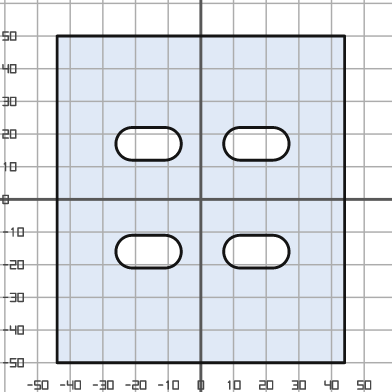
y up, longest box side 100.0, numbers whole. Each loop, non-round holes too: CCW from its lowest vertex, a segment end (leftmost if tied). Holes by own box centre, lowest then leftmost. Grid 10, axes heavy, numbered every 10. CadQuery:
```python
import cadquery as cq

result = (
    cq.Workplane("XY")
    .moveTo(-44.0, -50.0)
    .lineTo(44.0, -50.0)
    .lineTo(44.0, 50.0)
    .lineTo(-44.0, 50.0)
    .close()
    .moveTo(-21.0, -21.0)
    .lineTo(-11.0, -21.0)
    .threePointArc((-6.0, -16.0), (-11.0, -11.0))
    .lineTo(-21.0, -11.0)
    .threePointArc((-26.0, -16.0), (-21.0, -21.0))
    .close()
    .moveTo(12.0, -21.0)
    .lineTo(22.0, -21.0)
    .threePointArc((27.0, -16.0), (22.0, -11.0))
    .lineTo(12.0, -11.0)
    .threePointArc((7.0, -16.0), (12.0, -21.0))
    .close()
    .moveTo(-21.0, 12.0)
    .lineTo(-11.0, 12.0)
    .threePointArc((-6.0, 17.0), (-11.0, 22.0))
    .lineTo(-21.0, 22.0)
    .threePointArc((-26.0, 17.0), (-21.0, 12.0))
    .close()
    .moveTo(12.0, 12.0)
    .lineTo(22.0, 12.0)
    .threePointArc((27.0, 17.0), (22.0, 22.0))
    .lineTo(12.0, 22.0)
    .threePointArc((7.0, 17.0), (12.0, 12.0))
    .close()
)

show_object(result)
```